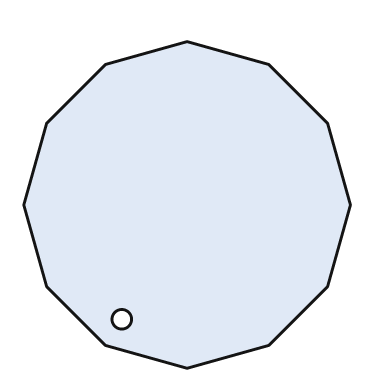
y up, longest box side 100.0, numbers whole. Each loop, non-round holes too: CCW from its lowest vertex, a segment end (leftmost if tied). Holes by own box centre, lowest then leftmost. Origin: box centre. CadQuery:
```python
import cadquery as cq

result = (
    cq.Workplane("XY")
    .moveTo(0.0, -50.0)
    .lineTo(25.0, -43.0)
    .lineTo(43.0, -25.0)
    .lineTo(50.0, 0.0)
    .lineTo(43.0, 25.0)
    .lineTo(25.0, 43.0)
    .lineTo(0.0, 50.0)
    .lineTo(-25.0, 43.0)
    .lineTo(-43.0, 25.0)
    .lineTo(-50.0, 0.0)
    .lineTo(-43.0, -25.0)
    .lineTo(-25.0, -43.0)
    .close()
    .moveTo(-20.0, -35.0)
    .circle(3.0)
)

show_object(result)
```